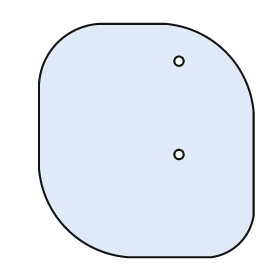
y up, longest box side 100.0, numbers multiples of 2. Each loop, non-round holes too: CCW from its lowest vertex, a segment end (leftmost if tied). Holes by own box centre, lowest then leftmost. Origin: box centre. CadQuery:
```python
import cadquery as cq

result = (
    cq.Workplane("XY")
    .moveTo(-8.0, -50.0)
    .lineTo(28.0, -50.0)
    .threePointArc((40.0, -44.0), (46.0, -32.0))
    .lineTo(46.0, 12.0)
    .threePointArc((34.0, 38.0), (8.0, 50.0))
    .lineTo(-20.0, 50.0)
    .threePointArc((-38.0, 42.0), (-46.0, 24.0))
    .lineTo(-46.0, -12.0)
    .threePointArc((-34.0, -38.0), (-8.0, -50.0))
    .close()
    .moveTo(14.0, -6.0)
    .circle(2.0)
    .moveTo(14.0, 34.0)
    .circle(2.0)
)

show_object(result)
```